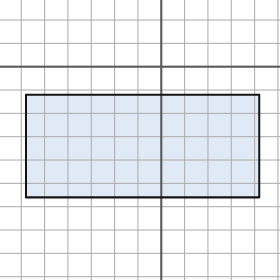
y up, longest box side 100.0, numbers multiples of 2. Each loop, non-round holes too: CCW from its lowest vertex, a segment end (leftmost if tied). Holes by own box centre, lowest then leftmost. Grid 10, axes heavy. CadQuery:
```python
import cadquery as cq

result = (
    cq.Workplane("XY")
    .moveTo(-58.0, -56.0)
    .lineTo(42.0, -56.0)
    .lineTo(42.0, -12.0)
    .lineTo(-58.0, -12.0)
    .close()
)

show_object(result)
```